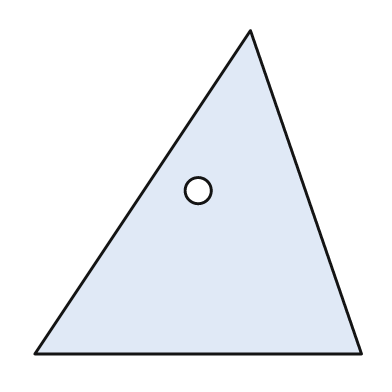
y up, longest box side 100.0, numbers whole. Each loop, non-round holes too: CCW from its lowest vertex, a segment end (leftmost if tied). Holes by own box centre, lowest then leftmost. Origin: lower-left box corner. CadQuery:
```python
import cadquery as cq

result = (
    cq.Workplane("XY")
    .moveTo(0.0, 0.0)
    .lineTo(100.0, 0.0)
    .lineTo(66.0, 99.0)
    .close()
    .moveTo(50.0, 50.0)
    .circle(4.0)
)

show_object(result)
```